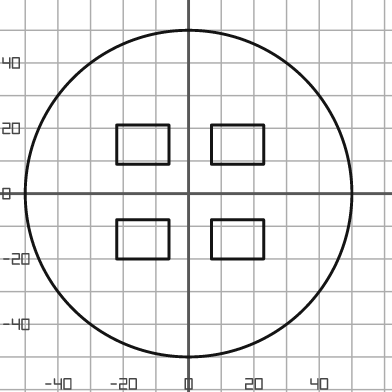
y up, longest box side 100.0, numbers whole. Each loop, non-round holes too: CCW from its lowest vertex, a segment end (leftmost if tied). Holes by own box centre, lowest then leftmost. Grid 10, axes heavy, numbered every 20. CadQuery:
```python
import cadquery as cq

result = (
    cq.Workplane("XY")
    .moveTo(0.0, 0.0)
    .circle(50.0)
    .moveTo(-22.0, -20.0)
    .lineTo(-6.0, -20.0)
    .lineTo(-6.0, -8.0)
    .lineTo(-22.0, -8.0)
    .close()
    .moveTo(7.0, -20.0)
    .lineTo(23.0, -20.0)
    .lineTo(23.0, -8.0)
    .lineTo(7.0, -8.0)
    .close()
    .moveTo(-22.0, 9.0)
    .lineTo(-6.0, 9.0)
    .lineTo(-6.0, 21.0)
    .lineTo(-22.0, 21.0)
    .close()
    .moveTo(7.0, 9.0)
    .lineTo(23.0, 9.0)
    .lineTo(23.0, 21.0)
    .lineTo(7.0, 21.0)
    .close()
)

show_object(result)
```